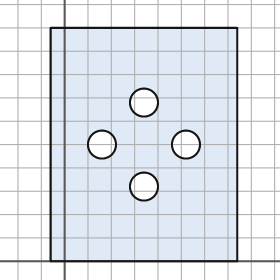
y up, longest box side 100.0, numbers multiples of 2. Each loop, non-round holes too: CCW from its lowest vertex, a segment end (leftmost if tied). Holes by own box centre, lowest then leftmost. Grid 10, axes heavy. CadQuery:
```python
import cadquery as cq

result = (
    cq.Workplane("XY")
    .moveTo(-6.0, 0.0)
    .lineTo(74.0, 0.0)
    .lineTo(74.0, 100.0)
    .lineTo(-6.0, 100.0)
    .close()
    .moveTo(34.0, 32.0)
    .circle(6.0)
    .moveTo(16.0, 50.0)
    .circle(6.0)
    .moveTo(52.0, 50.0)
    .circle(6.0)
    .moveTo(34.0, 68.0)
    .circle(6.0)
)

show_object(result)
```